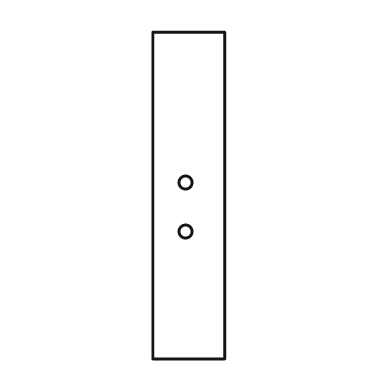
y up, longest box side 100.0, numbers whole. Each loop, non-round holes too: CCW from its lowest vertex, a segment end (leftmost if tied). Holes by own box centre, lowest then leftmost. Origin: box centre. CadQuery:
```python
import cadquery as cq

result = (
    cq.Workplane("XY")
    .moveTo(-11.0, -50.0)
    .lineTo(11.0, -50.0)
    .lineTo(11.0, 50.0)
    .lineTo(-11.0, 50.0)
    .close()
    .moveTo(-1.0, -11.0)
    .circle(2.0)
    .moveTo(-1.0, 4.0)
    .circle(2.0)
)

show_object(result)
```